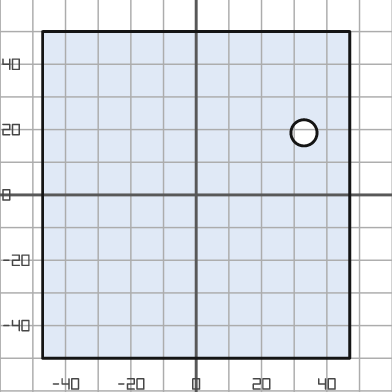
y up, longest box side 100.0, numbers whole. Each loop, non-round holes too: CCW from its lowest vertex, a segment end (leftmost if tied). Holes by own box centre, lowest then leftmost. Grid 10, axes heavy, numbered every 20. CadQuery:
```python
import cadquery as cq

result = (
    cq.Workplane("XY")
    .moveTo(-47.0, -50.0)
    .lineTo(47.0, -50.0)
    .lineTo(47.0, 50.0)
    .lineTo(-47.0, 50.0)
    .close()
    .moveTo(33.0, 19.0)
    .circle(4.0)
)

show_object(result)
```